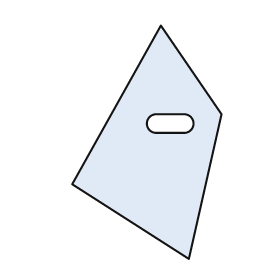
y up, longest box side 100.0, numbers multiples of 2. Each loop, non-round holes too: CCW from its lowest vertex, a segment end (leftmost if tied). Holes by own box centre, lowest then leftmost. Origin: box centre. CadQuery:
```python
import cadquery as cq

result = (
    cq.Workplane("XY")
    .moveTo(18.0, -50.0)
    .lineTo(32.0, 12.0)
    .lineTo(6.0, 50.0)
    .lineTo(-32.0, -18.0)
    .close()
    .moveTo(4.0, 4.0)
    .lineTo(16.0, 4.0)
    .threePointArc((20.0, 8.0), (16.0, 12.0))
    .lineTo(4.0, 12.0)
    .threePointArc((0.0, 8.0), (4.0, 4.0))
    .close()
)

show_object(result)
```